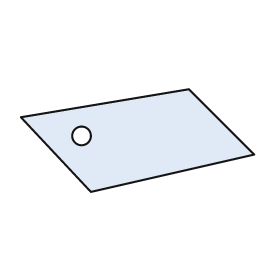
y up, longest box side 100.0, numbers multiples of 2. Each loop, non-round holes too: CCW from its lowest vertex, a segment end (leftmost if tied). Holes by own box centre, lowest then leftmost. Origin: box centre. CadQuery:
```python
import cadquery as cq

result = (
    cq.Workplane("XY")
    .moveTo(-20.0, -22.0)
    .lineTo(50.0, -6.0)
    .lineTo(22.0, 22.0)
    .lineTo(-50.0, 10.0)
    .close()
    .moveTo(-24.0, 2.0)
    .circle(4.0)
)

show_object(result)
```